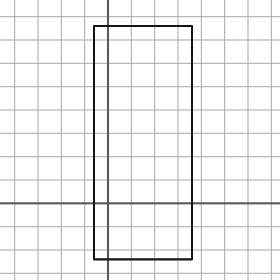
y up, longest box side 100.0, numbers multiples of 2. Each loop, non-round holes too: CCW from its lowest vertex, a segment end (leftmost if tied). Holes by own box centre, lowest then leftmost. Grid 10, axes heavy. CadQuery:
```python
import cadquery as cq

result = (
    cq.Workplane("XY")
    .moveTo(-6.0, -24.0)
    .lineTo(36.0, -24.0)
    .lineTo(36.0, 76.0)
    .lineTo(-6.0, 76.0)
    .close()
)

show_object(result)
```